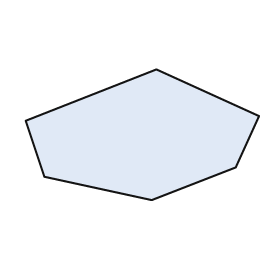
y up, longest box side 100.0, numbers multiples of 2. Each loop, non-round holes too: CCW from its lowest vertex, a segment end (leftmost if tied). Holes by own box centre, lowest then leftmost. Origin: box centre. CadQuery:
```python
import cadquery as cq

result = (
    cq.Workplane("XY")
    .moveTo(4.0, -28.0)
    .lineTo(40.0, -14.0)
    .lineTo(50.0, 8.0)
    .lineTo(6.0, 28.0)
    .lineTo(-50.0, 6.0)
    .lineTo(-42.0, -18.0)
    .close()
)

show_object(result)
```